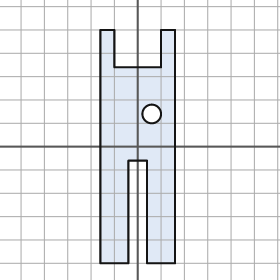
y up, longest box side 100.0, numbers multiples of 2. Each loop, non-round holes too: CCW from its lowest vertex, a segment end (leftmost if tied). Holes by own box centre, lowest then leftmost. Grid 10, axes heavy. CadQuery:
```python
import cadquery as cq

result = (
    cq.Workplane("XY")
    .moveTo(-16.0, -50.0)
    .lineTo(-4.0, -50.0)
    .lineTo(-4.0, -6.0)
    .lineTo(4.0, -6.0)
    .lineTo(4.0, -50.0)
    .lineTo(16.0, -50.0)
    .lineTo(16.0, 50.0)
    .lineTo(10.0, 50.0)
    .lineTo(10.0, 34.0)
    .lineTo(-10.0, 34.0)
    .lineTo(-10.0, 50.0)
    .lineTo(-16.0, 50.0)
    .close()
    .moveTo(6.0, 14.0)
    .circle(4.0)
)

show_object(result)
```